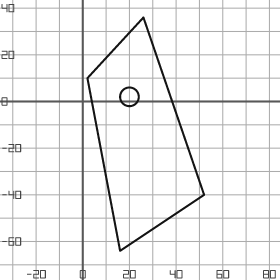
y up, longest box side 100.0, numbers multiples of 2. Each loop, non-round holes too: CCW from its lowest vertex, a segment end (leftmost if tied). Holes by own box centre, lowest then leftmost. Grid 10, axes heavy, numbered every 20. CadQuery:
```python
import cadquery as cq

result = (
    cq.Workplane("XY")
    .moveTo(16.0, -64.0)
    .lineTo(52.0, -40.0)
    .lineTo(26.0, 36.0)
    .lineTo(2.0, 10.0)
    .close()
    .moveTo(20.0, 2.0)
    .circle(4.0)
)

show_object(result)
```